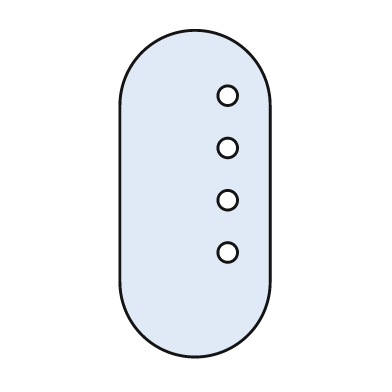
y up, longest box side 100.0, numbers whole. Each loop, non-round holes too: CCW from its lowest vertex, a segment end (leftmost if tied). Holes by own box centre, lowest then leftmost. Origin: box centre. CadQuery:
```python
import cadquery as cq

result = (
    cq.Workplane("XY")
    .moveTo(-23.0, -27.0)
    .threePointArc((0.0, -50.0), (23.0, -27.0))
    .lineTo(23.0, 27.0)
    .threePointArc((0.0, 50.0), (-23.0, 27.0))
    .close()
    .moveTo(10.0, -18.0)
    .circle(3.0)
    .moveTo(10.0, -2.0)
    .circle(3.0)
    .moveTo(10.0, 14.0)
    .circle(3.0)
    .moveTo(10.0, 30.0)
    .circle(3.0)
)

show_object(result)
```